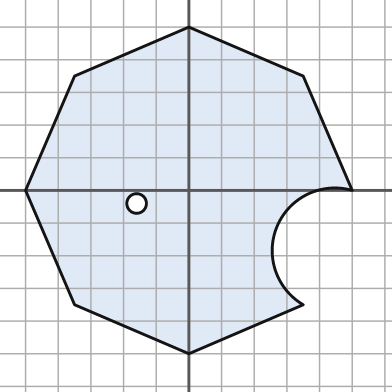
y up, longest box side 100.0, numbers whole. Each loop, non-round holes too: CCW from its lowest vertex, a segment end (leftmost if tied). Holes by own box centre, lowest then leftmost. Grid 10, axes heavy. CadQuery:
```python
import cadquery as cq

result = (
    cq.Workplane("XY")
    .moveTo(0.0, -50.0)
    .lineTo(35.0, -35.0)
    .threePointArc((27.0, -11.0), (50.0, 0.0))
    .lineTo(35.0, 35.0)
    .lineTo(0.0, 50.0)
    .lineTo(-35.0, 35.0)
    .lineTo(-50.0, 0.0)
    .lineTo(-35.0, -35.0)
    .close()
    .moveTo(-16.0, -4.0)
    .circle(3.0)
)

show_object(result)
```